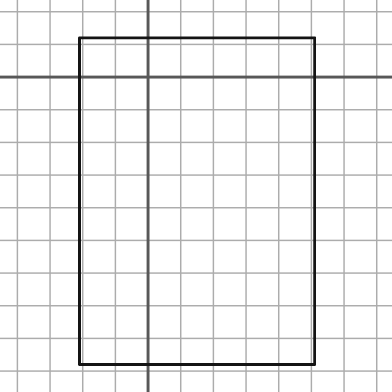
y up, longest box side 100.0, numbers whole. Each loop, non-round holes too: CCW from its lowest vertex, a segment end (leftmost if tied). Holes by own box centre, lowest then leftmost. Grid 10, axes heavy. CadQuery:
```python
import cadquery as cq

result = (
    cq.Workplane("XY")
    .moveTo(-21.0, -88.0)
    .lineTo(51.0, -88.0)
    .lineTo(51.0, 12.0)
    .lineTo(-21.0, 12.0)
    .close()
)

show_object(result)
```